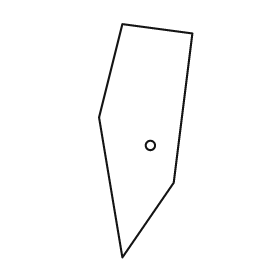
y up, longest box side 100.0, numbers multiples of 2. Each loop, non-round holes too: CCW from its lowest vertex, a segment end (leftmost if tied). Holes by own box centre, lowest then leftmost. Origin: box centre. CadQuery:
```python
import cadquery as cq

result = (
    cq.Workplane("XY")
    .moveTo(-10.0, -50.0)
    .lineTo(12.0, -18.0)
    .lineTo(20.0, 46.0)
    .lineTo(-10.0, 50.0)
    .lineTo(-20.0, 10.0)
    .close()
    .moveTo(2.0, -2.0)
    .circle(2.0)
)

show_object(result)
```